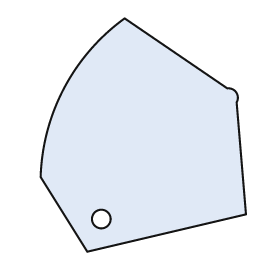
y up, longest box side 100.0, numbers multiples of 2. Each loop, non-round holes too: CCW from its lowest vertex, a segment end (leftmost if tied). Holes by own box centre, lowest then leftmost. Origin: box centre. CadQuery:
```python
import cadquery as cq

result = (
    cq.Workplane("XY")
    .moveTo(-24.0, -50.0)
    .lineTo(44.0, -34.0)
    .lineTo(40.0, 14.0)
    .threePointArc((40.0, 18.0), (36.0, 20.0))
    .lineTo(-8.0, 50.0)
    .threePointArc((-34.0, 20.0), (-44.0, -18.0))
    .close()
    .moveTo(-18.0, -36.0)
    .circle(4.0)
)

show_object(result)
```